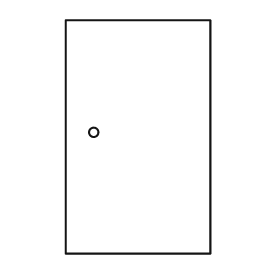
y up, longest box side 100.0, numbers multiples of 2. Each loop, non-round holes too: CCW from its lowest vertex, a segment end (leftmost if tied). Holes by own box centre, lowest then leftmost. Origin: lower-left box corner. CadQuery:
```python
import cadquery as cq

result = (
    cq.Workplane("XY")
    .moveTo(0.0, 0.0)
    .lineTo(62.0, 0.0)
    .lineTo(62.0, 100.0)
    .lineTo(0.0, 100.0)
    .close()
    .moveTo(12.0, 52.0)
    .circle(2.0)
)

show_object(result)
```